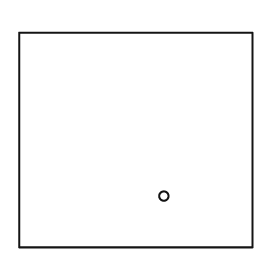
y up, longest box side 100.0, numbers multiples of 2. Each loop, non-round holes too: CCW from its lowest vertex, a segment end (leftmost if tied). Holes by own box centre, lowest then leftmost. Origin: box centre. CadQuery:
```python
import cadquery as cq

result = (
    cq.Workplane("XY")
    .moveTo(-50.0, -46.0)
    .lineTo(50.0, -46.0)
    .lineTo(50.0, 46.0)
    .lineTo(-50.0, 46.0)
    .close()
    .moveTo(12.0, -24.0)
    .circle(2.0)
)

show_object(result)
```